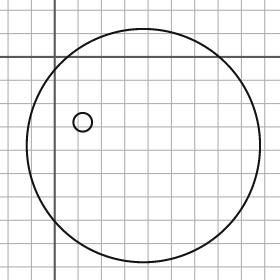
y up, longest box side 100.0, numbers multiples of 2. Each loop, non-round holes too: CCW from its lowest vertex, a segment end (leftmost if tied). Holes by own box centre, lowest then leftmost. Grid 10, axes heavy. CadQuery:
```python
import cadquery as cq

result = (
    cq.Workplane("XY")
    .moveTo(38.0, -38.0)
    .circle(50.0)
    .moveTo(12.0, -28.0)
    .circle(4.0)
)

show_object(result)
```